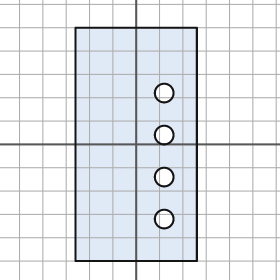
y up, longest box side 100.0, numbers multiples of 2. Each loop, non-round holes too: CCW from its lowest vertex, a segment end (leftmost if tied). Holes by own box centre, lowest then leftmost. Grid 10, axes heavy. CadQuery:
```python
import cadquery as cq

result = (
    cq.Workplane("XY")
    .moveTo(-26.0, -50.0)
    .lineTo(26.0, -50.0)
    .lineTo(26.0, 50.0)
    .lineTo(-26.0, 50.0)
    .close()
    .moveTo(12.0, -32.0)
    .circle(4.0)
    .moveTo(12.0, -14.0)
    .circle(4.0)
    .moveTo(12.0, 4.0)
    .circle(4.0)
    .moveTo(12.0, 22.0)
    .circle(4.0)
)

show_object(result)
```